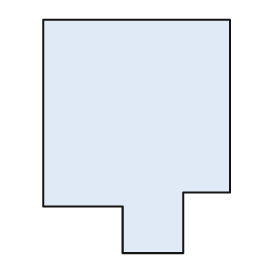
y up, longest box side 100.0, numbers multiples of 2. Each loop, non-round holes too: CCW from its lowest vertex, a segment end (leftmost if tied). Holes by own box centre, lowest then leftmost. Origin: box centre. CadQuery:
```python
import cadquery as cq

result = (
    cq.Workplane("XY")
    .moveTo(-6.0, -50.0)
    .lineTo(20.0, -50.0)
    .lineTo(20.0, -24.0)
    .lineTo(40.0, -24.0)
    .lineTo(40.0, 50.0)
    .lineTo(-40.0, 50.0)
    .lineTo(-40.0, -30.0)
    .lineTo(-6.0, -30.0)
    .close()
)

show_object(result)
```